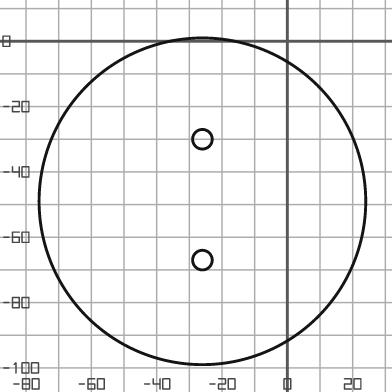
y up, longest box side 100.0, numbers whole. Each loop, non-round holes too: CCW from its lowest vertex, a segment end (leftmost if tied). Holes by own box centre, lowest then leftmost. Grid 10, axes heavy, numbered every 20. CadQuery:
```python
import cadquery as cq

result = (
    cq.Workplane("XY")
    .moveTo(-26.0, -49.0)
    .circle(50.0)
    .moveTo(-26.0, -67.0)
    .circle(3.0)
    .moveTo(-26.0, -30.0)
    .circle(3.0)
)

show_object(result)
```